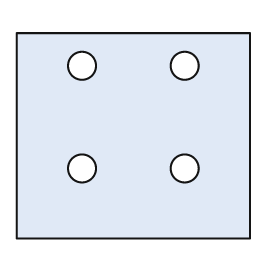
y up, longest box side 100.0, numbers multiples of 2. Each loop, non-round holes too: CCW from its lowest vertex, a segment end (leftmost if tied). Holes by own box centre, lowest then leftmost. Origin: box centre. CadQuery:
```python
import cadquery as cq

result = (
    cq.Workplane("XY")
    .moveTo(-50.0, -44.0)
    .lineTo(50.0, -44.0)
    .lineTo(50.0, 44.0)
    .lineTo(-50.0, 44.0)
    .close()
    .moveTo(-22.0, -14.0)
    .circle(6.0)
    .moveTo(22.0, -14.0)
    .circle(6.0)
    .moveTo(-22.0, 30.0)
    .circle(6.0)
    .moveTo(22.0, 30.0)
    .circle(6.0)
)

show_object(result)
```